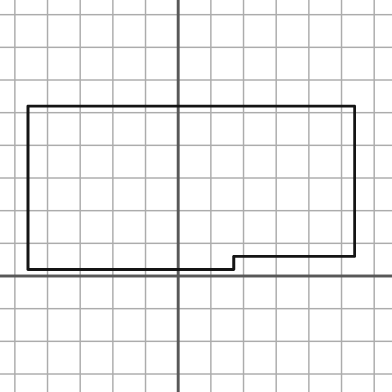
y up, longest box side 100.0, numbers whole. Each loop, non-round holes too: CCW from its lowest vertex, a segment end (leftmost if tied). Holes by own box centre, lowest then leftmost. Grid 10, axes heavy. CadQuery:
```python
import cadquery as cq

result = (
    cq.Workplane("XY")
    .moveTo(-46.0, 2.0)
    .lineTo(17.0, 2.0)
    .lineTo(17.0, 6.0)
    .lineTo(54.0, 6.0)
    .lineTo(54.0, 52.0)
    .lineTo(-46.0, 52.0)
    .close()
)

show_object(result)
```